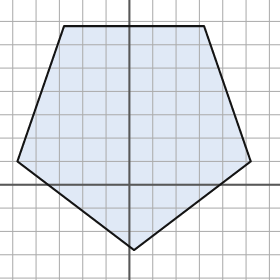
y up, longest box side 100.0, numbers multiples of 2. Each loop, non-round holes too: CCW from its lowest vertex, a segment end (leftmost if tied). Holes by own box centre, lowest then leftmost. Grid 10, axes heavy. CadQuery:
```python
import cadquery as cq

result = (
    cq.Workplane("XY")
    .moveTo(2.0, -28.0)
    .lineTo(52.0, 10.0)
    .lineTo(32.0, 68.0)
    .lineTo(-28.0, 68.0)
    .lineTo(-48.0, 10.0)
    .close()
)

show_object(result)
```